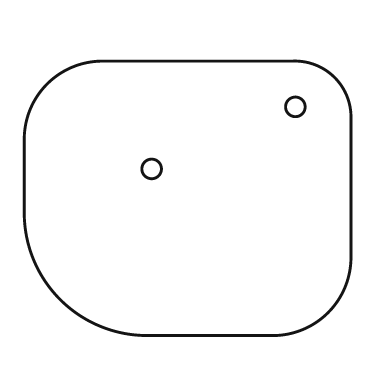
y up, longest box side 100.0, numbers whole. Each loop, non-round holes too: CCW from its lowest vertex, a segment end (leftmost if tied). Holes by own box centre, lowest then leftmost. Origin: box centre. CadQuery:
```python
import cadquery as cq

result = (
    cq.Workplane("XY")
    .moveTo(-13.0, -42.0)
    .lineTo(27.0, -42.0)
    .threePointArc((43.0, -35.0), (50.0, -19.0))
    .lineTo(50.0, 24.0)
    .threePointArc((45.0, 37.0), (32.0, 42.0))
    .lineTo(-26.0, 42.0)
    .threePointArc((-43.0, 35.0), (-50.0, 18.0))
    .lineTo(-50.0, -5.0)
    .threePointArc((-39.0, -31.0), (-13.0, -42.0))
    .close()
    .moveTo(-11.0, 9.0)
    .circle(3.0)
    .moveTo(33.0, 28.0)
    .circle(3.0)
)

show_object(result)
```